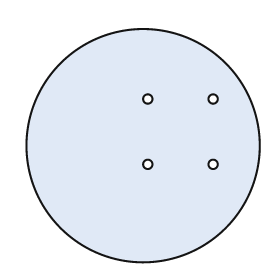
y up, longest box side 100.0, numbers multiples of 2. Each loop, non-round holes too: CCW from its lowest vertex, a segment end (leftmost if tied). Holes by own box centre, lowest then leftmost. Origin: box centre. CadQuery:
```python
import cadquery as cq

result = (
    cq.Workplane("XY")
    .moveTo(0.0, 0.0)
    .circle(50.0)
    .moveTo(2.0, -8.0)
    .circle(2.0)
    .moveTo(30.0, -8.0)
    .circle(2.0)
    .moveTo(2.0, 20.0)
    .circle(2.0)
    .moveTo(30.0, 20.0)
    .circle(2.0)
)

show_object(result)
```